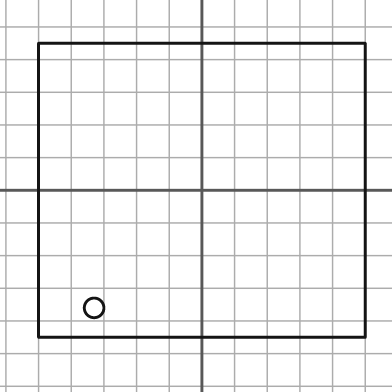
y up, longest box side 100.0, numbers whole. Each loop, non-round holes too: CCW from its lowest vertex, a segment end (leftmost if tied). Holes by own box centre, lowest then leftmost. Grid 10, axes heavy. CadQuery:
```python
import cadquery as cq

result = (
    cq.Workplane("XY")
    .moveTo(-50.0, -45.0)
    .lineTo(50.0, -45.0)
    .lineTo(50.0, 45.0)
    .lineTo(-50.0, 45.0)
    .close()
    .moveTo(-33.0, -36.0)
    .circle(3.0)
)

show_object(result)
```